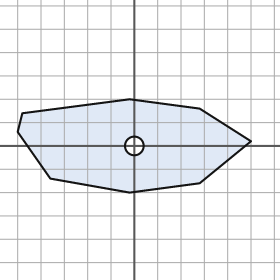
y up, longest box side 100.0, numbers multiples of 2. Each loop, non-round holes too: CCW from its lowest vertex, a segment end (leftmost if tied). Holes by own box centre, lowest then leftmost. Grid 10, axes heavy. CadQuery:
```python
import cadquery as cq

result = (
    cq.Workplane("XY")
    .moveTo(-2.0, -20.0)
    .lineTo(28.0, -16.0)
    .lineTo(50.0, 2.0)
    .lineTo(28.0, 16.0)
    .lineTo(-2.0, 20.0)
    .lineTo(-48.0, 14.0)
    .lineTo(-50.0, 6.0)
    .lineTo(-36.0, -14.0)
    .close()
    .moveTo(0.0, 0.0)
    .circle(4.0)
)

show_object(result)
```